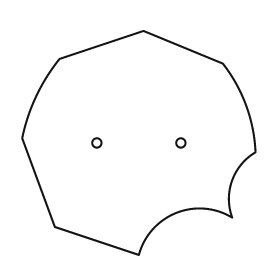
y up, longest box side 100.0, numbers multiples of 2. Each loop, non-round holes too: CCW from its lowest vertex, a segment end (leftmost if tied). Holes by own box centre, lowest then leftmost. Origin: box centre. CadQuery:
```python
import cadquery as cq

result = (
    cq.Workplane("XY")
    .moveTo(0.0, -48.0)
    .threePointArc((16.0, -30.0), (40.0, -32.0))
    .threePointArc((40.0, -16.0), (50.0, -4.0))
    .threePointArc((46.0, 16.0), (36.0, 34.0))
    .lineTo(2.0, 48.0)
    .lineTo(-34.0, 36.0)
    .threePointArc((-44.0, 20.0), (-50.0, 2.0))
    .lineTo(-36.0, -36.0)
    .close()
    .moveTo(-18.0, 0.0)
    .circle(2.0)
    .moveTo(18.0, 0.0)
    .circle(2.0)
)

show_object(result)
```